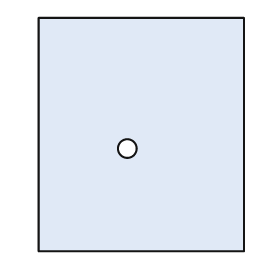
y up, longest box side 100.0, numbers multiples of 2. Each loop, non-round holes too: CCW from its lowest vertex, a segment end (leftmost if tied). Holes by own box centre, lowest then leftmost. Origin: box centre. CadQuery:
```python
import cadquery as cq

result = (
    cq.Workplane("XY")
    .moveTo(-44.0, -50.0)
    .lineTo(44.0, -50.0)
    .lineTo(44.0, 50.0)
    .lineTo(-44.0, 50.0)
    .close()
    .moveTo(-6.0, -6.0)
    .circle(4.0)
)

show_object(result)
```